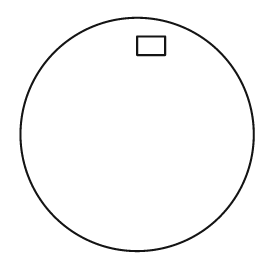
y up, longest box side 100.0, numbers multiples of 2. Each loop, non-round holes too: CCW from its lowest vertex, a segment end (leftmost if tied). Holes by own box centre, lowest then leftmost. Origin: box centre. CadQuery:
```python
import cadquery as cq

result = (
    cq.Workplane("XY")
    .moveTo(0.0, 0.0)
    .circle(50.0)
    .moveTo(0.0, 34.0)
    .lineTo(12.0, 34.0)
    .lineTo(12.0, 42.0)
    .lineTo(0.0, 42.0)
    .close()
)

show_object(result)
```